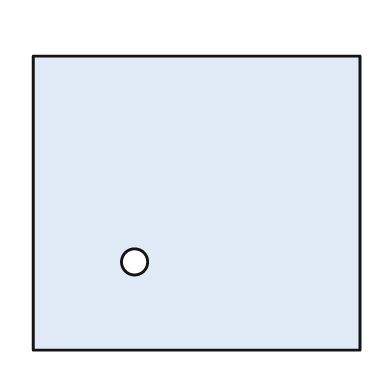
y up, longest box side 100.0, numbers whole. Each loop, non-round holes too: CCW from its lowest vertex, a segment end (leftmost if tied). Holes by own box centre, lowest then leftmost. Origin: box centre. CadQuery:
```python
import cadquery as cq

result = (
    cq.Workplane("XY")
    .moveTo(-50.0, -45.0)
    .lineTo(50.0, -45.0)
    .lineTo(50.0, 45.0)
    .lineTo(-50.0, 45.0)
    .close()
    .moveTo(-19.0, -18.0)
    .circle(4.0)
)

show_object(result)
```